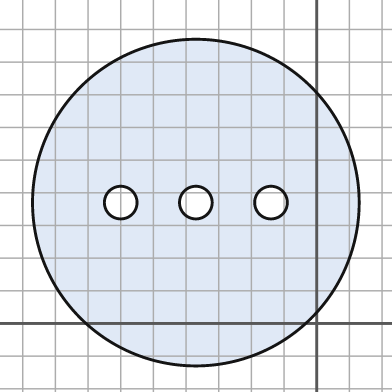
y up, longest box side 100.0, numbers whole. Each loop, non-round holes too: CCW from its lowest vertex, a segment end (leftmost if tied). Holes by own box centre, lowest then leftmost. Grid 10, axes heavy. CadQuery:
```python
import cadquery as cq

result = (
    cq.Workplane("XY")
    .moveTo(-37.0, 37.0)
    .circle(50.0)
    .moveTo(-60.0, 37.0)
    .circle(5.0)
    .moveTo(-37.0, 37.0)
    .circle(5.0)
    .moveTo(-14.0, 37.0)
    .circle(5.0)
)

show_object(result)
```